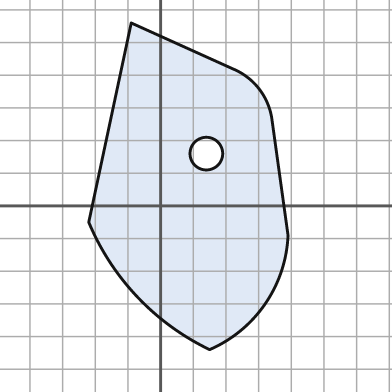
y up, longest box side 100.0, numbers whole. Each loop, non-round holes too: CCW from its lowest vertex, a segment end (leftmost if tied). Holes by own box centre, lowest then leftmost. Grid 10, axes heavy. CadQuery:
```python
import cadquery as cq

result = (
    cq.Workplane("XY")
    .moveTo(15.0, -44.0)
    .threePointArc((32.0, -30.0), (39.0, -9.0))
    .lineTo(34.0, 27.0)
    .threePointArc((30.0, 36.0), (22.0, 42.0))
    .lineTo(-9.0, 56.0)
    .lineTo(-22.0, -5.0)
    .threePointArc((-7.0, -28.0), (15.0, -44.0))
    .close()
    .moveTo(14.0, 16.0)
    .circle(5.0)
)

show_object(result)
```